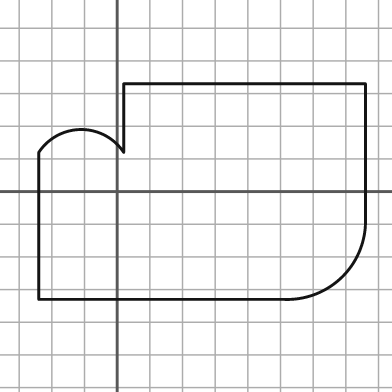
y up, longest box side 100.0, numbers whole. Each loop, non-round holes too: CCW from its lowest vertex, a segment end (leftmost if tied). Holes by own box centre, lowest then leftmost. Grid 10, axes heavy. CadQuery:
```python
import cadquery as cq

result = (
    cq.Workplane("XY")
    .moveTo(-24.0, -33.0)
    .lineTo(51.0, -33.0)
    .threePointArc((69.0, -26.0), (76.0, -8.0))
    .lineTo(76.0, 33.0)
    .lineTo(2.0, 33.0)
    .lineTo(2.0, 12.0)
    .threePointArc((-11.0, 19.0), (-24.0, 12.0))
    .close()
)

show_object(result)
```